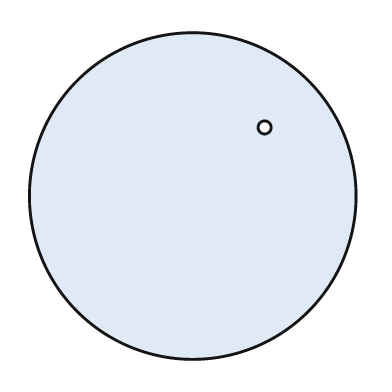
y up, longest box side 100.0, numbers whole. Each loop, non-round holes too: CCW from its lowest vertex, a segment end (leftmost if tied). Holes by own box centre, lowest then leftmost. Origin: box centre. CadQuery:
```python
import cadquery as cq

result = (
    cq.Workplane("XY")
    .moveTo(0.0, 0.0)
    .circle(50.0)
    .moveTo(22.0, 21.0)
    .circle(2.0)
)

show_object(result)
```